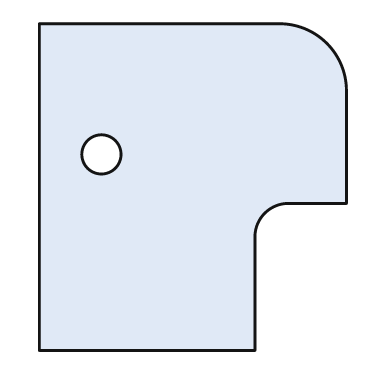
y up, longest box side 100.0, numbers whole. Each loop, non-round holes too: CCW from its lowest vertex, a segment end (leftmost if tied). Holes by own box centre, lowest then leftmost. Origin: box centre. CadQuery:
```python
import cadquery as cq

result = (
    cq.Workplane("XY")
    .moveTo(-47.0, -50.0)
    .lineTo(19.0, -50.0)
    .lineTo(19.0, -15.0)
    .threePointArc((22.0, -8.0), (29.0, -5.0))
    .lineTo(47.0, -5.0)
    .lineTo(47.0, 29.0)
    .threePointArc((41.0, 44.0), (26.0, 50.0))
    .lineTo(-47.0, 50.0)
    .close()
    .moveTo(-28.0, 10.0)
    .circle(6.0)
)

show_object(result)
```